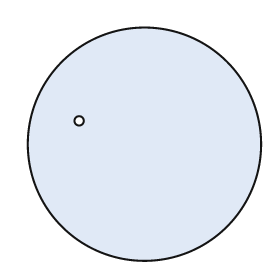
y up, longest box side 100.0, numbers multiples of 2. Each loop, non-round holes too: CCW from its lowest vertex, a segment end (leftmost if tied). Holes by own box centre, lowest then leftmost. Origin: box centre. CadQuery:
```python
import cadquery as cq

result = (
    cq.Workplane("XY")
    .moveTo(0.0, 0.0)
    .circle(50.0)
    .moveTo(-28.0, 10.0)
    .circle(2.0)
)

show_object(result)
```